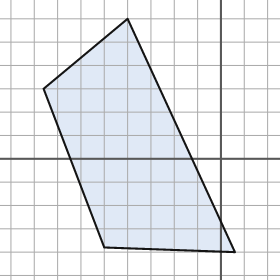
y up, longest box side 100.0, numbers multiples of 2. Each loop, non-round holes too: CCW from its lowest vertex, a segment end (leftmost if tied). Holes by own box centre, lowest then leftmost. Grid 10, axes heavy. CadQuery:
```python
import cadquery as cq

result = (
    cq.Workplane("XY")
    .moveTo(6.0, -40.0)
    .lineTo(-40.0, 60.0)
    .lineTo(-76.0, 30.0)
    .lineTo(-50.0, -38.0)
    .close()
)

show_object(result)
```